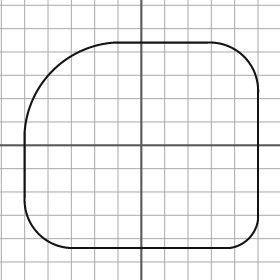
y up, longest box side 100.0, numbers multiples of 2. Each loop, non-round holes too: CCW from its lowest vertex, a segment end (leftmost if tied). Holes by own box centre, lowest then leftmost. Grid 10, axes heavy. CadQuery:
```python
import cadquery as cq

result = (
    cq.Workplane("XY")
    .moveTo(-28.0, -44.0)
    .lineTo(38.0, -44.0)
    .threePointArc((46.0, -40.0), (50.0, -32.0))
    .lineTo(50.0, 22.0)
    .threePointArc((44.0, 38.0), (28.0, 44.0))
    .lineTo(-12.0, 44.0)
    .threePointArc((-38.0, 32.0), (-50.0, 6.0))
    .lineTo(-50.0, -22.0)
    .threePointArc((-44.0, -38.0), (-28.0, -44.0))
    .close()
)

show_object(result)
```